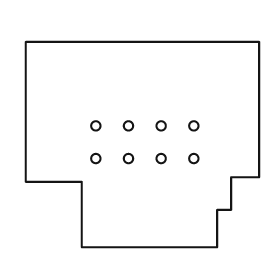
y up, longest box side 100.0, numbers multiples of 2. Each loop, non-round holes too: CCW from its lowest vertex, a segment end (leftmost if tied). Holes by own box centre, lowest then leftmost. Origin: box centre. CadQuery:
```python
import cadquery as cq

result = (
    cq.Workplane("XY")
    .moveTo(-26.0, -44.0)
    .lineTo(32.0, -44.0)
    .lineTo(32.0, -28.0)
    .lineTo(38.0, -28.0)
    .lineTo(38.0, -14.0)
    .lineTo(50.0, -14.0)
    .lineTo(50.0, 44.0)
    .lineTo(-50.0, 44.0)
    .lineTo(-50.0, -16.0)
    .lineTo(-26.0, -16.0)
    .close()
    .moveTo(-20.0, -6.0)
    .circle(2.0)
    .moveTo(-6.0, -6.0)
    .circle(2.0)
    .moveTo(8.0, -6.0)
    .circle(2.0)
    .moveTo(22.0, -6.0)
    .circle(2.0)
    .moveTo(-20.0, 8.0)
    .circle(2.0)
    .moveTo(-6.0, 8.0)
    .circle(2.0)
    .moveTo(8.0, 8.0)
    .circle(2.0)
    .moveTo(22.0, 8.0)
    .circle(2.0)
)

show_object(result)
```